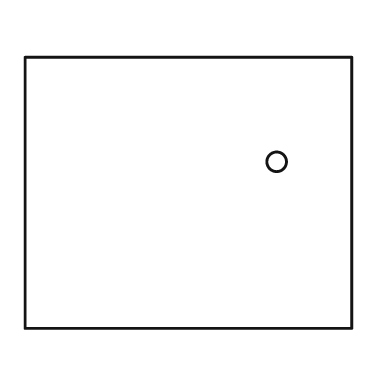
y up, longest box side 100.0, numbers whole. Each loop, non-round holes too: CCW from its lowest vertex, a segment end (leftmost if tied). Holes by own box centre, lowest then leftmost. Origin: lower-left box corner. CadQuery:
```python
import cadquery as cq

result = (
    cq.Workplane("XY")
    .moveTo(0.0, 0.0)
    .lineTo(100.0, 0.0)
    .lineTo(100.0, 83.0)
    .lineTo(0.0, 83.0)
    .close()
    .moveTo(77.0, 51.0)
    .circle(3.0)
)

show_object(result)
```